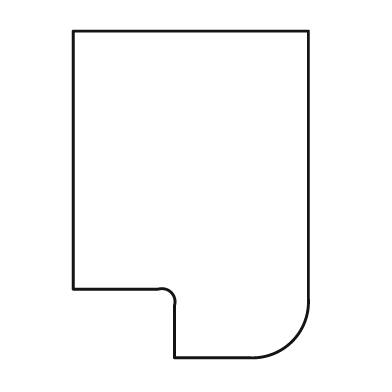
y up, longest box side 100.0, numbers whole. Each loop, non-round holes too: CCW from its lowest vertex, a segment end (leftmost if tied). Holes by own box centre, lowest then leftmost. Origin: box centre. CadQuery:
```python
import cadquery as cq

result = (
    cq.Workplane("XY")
    .moveTo(-5.0, -50.0)
    .lineTo(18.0, -50.0)
    .threePointArc((31.0, -45.0), (36.0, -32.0))
    .lineTo(36.0, 50.0)
    .lineTo(-36.0, 50.0)
    .lineTo(-36.0, -29.0)
    .lineTo(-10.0, -29.0)
    .threePointArc((-6.0, -30.0), (-5.0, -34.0))
    .close()
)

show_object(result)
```